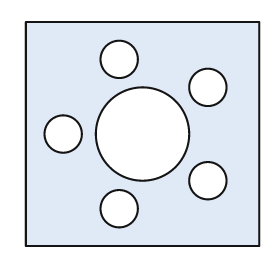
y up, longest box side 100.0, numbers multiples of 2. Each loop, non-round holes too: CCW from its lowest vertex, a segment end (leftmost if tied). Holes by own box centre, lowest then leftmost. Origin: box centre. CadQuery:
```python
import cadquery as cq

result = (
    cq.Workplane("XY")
    .moveTo(-50.0, -48.0)
    .lineTo(50.0, -48.0)
    .lineTo(50.0, 48.0)
    .lineTo(-50.0, 48.0)
    .close()
    .moveTo(-10.0, -32.0)
    .circle(8.0)
    .moveTo(28.0, -20.0)
    .circle(8.0)
    .moveTo(-34.0, 0.0)
    .circle(8.0)
    .moveTo(0.0, 0.0)
    .circle(20.0)
    .moveTo(28.0, 20.0)
    .circle(8.0)
    .moveTo(-10.0, 32.0)
    .circle(8.0)
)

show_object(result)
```